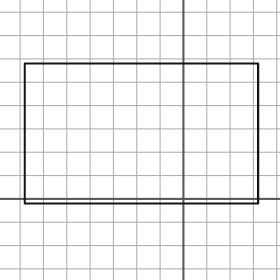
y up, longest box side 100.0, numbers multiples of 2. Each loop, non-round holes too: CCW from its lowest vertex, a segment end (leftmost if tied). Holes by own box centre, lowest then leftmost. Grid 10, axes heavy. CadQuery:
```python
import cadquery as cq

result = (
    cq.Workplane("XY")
    .moveTo(-68.0, -2.0)
    .lineTo(32.0, -2.0)
    .lineTo(32.0, 58.0)
    .lineTo(-68.0, 58.0)
    .close()
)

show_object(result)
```